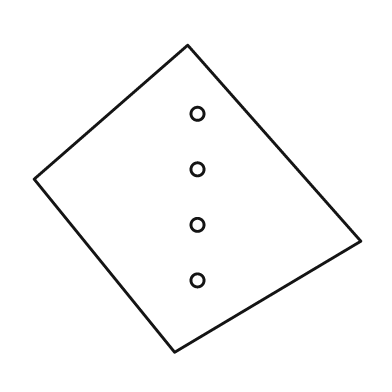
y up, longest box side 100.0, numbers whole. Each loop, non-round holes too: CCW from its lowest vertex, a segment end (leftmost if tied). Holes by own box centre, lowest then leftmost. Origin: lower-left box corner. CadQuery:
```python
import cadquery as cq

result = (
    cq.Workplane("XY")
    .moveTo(43.0, 0.0)
    .lineTo(100.0, 34.0)
    .lineTo(47.0, 94.0)
    .lineTo(0.0, 53.0)
    .close()
    .moveTo(50.0, 22.0)
    .circle(2.0)
    .moveTo(50.0, 39.0)
    .circle(2.0)
    .moveTo(50.0, 56.0)
    .circle(2.0)
    .moveTo(50.0, 73.0)
    .circle(2.0)
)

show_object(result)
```